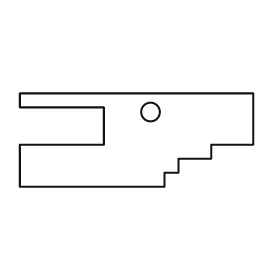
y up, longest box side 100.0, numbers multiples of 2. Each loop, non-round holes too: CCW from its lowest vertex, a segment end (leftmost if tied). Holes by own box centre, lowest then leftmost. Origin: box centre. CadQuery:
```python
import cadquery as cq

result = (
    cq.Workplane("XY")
    .moveTo(-50.0, -20.0)
    .lineTo(12.0, -20.0)
    .lineTo(12.0, -14.0)
    .lineTo(18.0, -14.0)
    .lineTo(18.0, -8.0)
    .lineTo(32.0, -8.0)
    .lineTo(32.0, -2.0)
    .lineTo(50.0, -2.0)
    .lineTo(50.0, 20.0)
    .lineTo(-50.0, 20.0)
    .lineTo(-50.0, 14.0)
    .lineTo(-14.0, 14.0)
    .lineTo(-14.0, -2.0)
    .lineTo(-50.0, -2.0)
    .close()
    .moveTo(6.0, 12.0)
    .circle(4.0)
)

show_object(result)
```